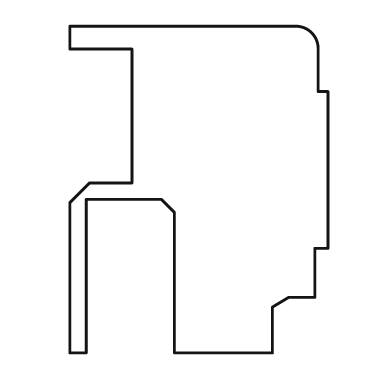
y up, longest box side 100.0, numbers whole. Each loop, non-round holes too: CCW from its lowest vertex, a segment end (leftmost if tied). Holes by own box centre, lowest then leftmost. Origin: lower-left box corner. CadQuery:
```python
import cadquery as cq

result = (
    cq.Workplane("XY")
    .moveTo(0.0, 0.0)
    .lineTo(5.0, 0.0)
    .lineTo(5.0, 47.0)
    .lineTo(28.0, 47.0)
    .lineTo(32.0, 43.0)
    .lineTo(32.0, 0.0)
    .lineTo(62.0, 0.0)
    .lineTo(62.0, 14.0)
    .lineTo(67.0, 17.0)
    .lineTo(75.0, 17.0)
    .lineTo(75.0, 32.0)
    .lineTo(79.0, 32.0)
    .lineTo(79.0, 80.0)
    .lineTo(76.0, 80.0)
    .lineTo(76.0, 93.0)
    .threePointArc((74.0, 98.0), (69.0, 100.0))
    .lineTo(0.0, 100.0)
    .lineTo(0.0, 93.0)
    .lineTo(19.0, 93.0)
    .lineTo(19.0, 52.0)
    .lineTo(6.0, 52.0)
    .lineTo(0.0, 46.0)
    .close()
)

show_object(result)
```